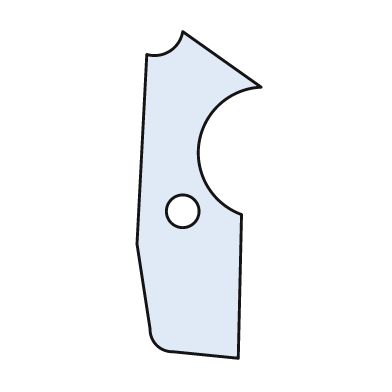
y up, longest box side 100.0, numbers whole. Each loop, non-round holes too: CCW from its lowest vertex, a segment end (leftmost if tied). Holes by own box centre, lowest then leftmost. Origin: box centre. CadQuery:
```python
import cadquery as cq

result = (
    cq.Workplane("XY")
    .moveTo(12.0, -50.0)
    .lineTo(13.0, -6.0)
    .threePointArc((0.0, 16.0), (19.0, 33.0))
    .lineTo(-5.0, 50.0)
    .threePointArc((-9.0, 44.0), (-16.0, 43.0))
    .lineTo(-19.0, -15.0)
    .lineTo(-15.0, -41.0)
    .threePointArc((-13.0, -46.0), (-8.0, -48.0))
    .close()
    .moveTo(-5.0, -5.0)
    .circle(5.0)
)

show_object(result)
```